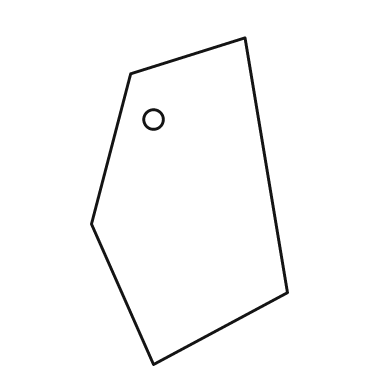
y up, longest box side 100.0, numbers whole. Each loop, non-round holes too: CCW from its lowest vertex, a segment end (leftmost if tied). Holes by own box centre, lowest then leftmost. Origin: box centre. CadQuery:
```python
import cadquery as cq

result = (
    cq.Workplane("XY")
    .moveTo(-11.0, -50.0)
    .lineTo(30.0, -28.0)
    .lineTo(17.0, 50.0)
    .lineTo(-18.0, 39.0)
    .lineTo(-30.0, -7.0)
    .close()
    .moveTo(-11.0, 25.0)
    .circle(3.0)
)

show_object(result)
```